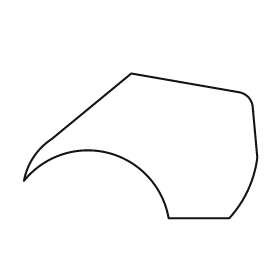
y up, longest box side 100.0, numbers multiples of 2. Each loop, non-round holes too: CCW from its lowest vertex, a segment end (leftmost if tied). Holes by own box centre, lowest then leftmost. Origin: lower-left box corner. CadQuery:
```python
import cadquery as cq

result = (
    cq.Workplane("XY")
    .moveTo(62.0, 0.0)
    .lineTo(88.0, 0.0)
    .threePointArc((96.0, 12.0), (100.0, 26.0))
    .lineTo(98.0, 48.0)
    .threePointArc((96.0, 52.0), (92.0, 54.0))
    .lineTo(46.0, 62.0)
    .lineTo(12.0, 34.0)
    .threePointArc((4.0, 26.0), (0.0, 16.0))
    .threePointArc((36.0, 28.0), (62.0, 0.0))
    .close()
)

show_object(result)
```